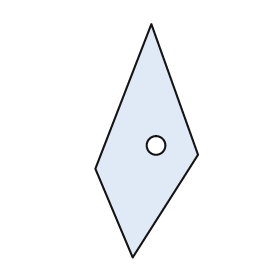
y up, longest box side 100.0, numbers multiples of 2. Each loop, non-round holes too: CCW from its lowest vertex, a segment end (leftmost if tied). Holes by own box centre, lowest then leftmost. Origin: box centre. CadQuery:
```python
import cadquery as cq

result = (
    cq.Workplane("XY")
    .moveTo(-6.0, -50.0)
    .lineTo(22.0, -6.0)
    .lineTo(2.0, 50.0)
    .lineTo(-22.0, -12.0)
    .close()
    .moveTo(4.0, -2.0)
    .circle(4.0)
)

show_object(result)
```